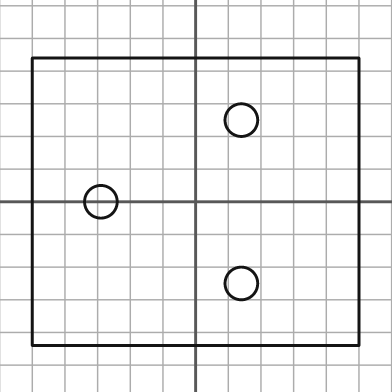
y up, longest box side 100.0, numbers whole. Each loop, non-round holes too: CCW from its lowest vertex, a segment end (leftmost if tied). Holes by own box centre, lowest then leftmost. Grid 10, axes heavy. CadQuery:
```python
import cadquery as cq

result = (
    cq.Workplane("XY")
    .moveTo(-50.0, -44.0)
    .lineTo(50.0, -44.0)
    .lineTo(50.0, 44.0)
    .lineTo(-50.0, 44.0)
    .close()
    .moveTo(14.0, -25.0)
    .circle(5.0)
    .moveTo(-29.0, 0.0)
    .circle(5.0)
    .moveTo(14.0, 25.0)
    .circle(5.0)
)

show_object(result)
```